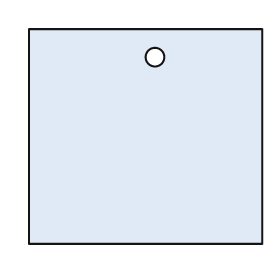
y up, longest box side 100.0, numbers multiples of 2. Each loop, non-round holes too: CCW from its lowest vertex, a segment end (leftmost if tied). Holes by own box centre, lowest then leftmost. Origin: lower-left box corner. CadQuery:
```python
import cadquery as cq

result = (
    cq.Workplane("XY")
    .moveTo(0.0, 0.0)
    .lineTo(100.0, 0.0)
    .lineTo(100.0, 92.0)
    .lineTo(0.0, 92.0)
    .close()
    .moveTo(54.0, 80.0)
    .circle(4.0)
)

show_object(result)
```